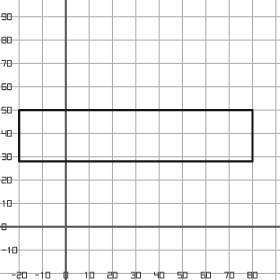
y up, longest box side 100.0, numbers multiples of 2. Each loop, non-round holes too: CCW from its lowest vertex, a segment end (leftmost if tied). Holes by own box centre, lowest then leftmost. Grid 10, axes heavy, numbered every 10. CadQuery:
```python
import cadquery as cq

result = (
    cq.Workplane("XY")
    .moveTo(-20.0, 28.0)
    .lineTo(80.0, 28.0)
    .lineTo(80.0, 50.0)
    .lineTo(-20.0, 50.0)
    .close()
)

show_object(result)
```